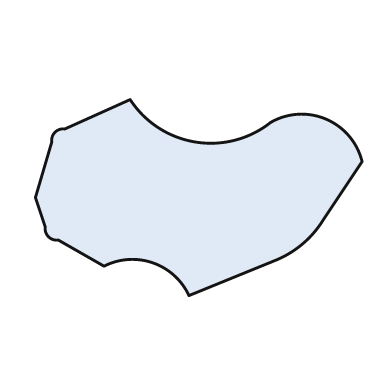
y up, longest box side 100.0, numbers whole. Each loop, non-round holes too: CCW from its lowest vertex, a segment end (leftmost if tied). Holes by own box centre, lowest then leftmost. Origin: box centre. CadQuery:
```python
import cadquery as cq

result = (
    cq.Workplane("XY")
    .moveTo(-3.0, -30.0)
    .lineTo(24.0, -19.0)
    .threePointArc((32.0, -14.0), (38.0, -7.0))
    .lineTo(50.0, 11.0)
    .threePointArc((39.0, 24.0), (22.0, 23.0))
    .threePointArc((-1.0, 17.0), (-21.0, 30.0))
    .lineTo(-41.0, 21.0)
    .threePointArc((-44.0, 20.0), (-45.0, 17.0))
    .lineTo(-50.0, 0.0)
    .lineTo(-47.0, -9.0)
    .threePointArc((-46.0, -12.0), (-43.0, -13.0))
    .lineTo(-29.0, -21.0)
    .threePointArc((-14.0, -20.0), (-3.0, -30.0))
    .close()
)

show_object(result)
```